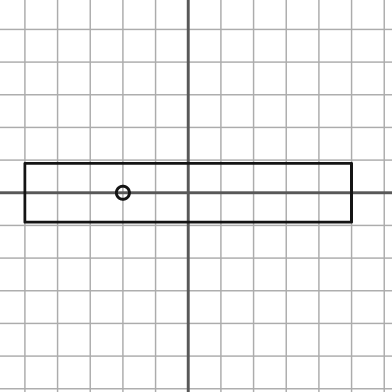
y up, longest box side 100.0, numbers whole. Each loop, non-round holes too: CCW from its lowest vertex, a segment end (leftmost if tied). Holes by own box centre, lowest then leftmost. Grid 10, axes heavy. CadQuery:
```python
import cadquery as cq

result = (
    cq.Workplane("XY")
    .moveTo(-50.0, -9.0)
    .lineTo(50.0, -9.0)
    .lineTo(50.0, 9.0)
    .lineTo(-50.0, 9.0)
    .close()
    .moveTo(-20.0, 0.0)
    .circle(2.0)
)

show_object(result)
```